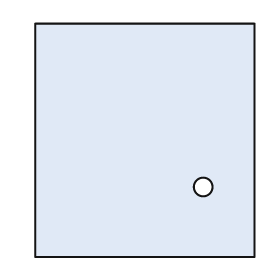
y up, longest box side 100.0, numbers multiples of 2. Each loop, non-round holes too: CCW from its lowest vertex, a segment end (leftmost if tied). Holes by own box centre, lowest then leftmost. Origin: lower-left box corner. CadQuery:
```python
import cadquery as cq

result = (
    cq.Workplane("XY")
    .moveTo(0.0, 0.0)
    .lineTo(94.0, 0.0)
    .lineTo(94.0, 100.0)
    .lineTo(0.0, 100.0)
    .close()
    .moveTo(72.0, 30.0)
    .circle(4.0)
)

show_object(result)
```